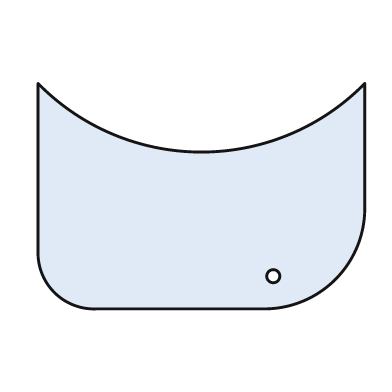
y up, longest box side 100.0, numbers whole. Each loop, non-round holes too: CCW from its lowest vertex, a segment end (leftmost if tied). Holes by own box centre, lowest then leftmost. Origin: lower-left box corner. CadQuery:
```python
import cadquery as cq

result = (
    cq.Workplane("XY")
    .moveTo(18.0, 0.0)
    .lineTo(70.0, 0.0)
    .threePointArc((91.0, 9.0), (100.0, 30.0))
    .lineTo(100.0, 69.0)
    .threePointArc((50.0, 48.0), (0.0, 69.0))
    .lineTo(0.0, 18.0)
    .threePointArc((5.0, 5.0), (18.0, 0.0))
    .close()
    .moveTo(72.0, 10.0)
    .circle(2.0)
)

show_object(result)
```